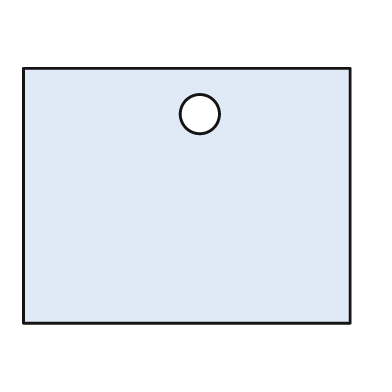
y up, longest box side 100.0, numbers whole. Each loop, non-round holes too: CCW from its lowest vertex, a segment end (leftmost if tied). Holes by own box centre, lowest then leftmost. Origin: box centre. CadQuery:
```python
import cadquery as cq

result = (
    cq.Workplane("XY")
    .moveTo(-50.0, -39.0)
    .lineTo(50.0, -39.0)
    .lineTo(50.0, 39.0)
    .lineTo(-50.0, 39.0)
    .close()
    .moveTo(4.0, 25.0)
    .circle(6.0)
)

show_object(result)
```